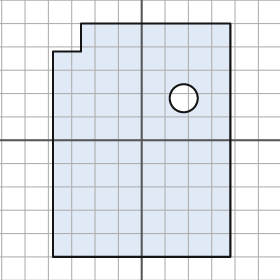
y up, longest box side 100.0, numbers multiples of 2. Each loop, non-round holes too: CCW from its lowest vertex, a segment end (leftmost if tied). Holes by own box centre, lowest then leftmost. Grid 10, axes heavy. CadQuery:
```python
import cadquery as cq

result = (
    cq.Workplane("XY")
    .moveTo(-38.0, -50.0)
    .lineTo(38.0, -50.0)
    .lineTo(38.0, 50.0)
    .lineTo(-26.0, 50.0)
    .lineTo(-26.0, 38.0)
    .lineTo(-38.0, 38.0)
    .close()
    .moveTo(18.0, 18.0)
    .circle(6.0)
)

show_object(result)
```